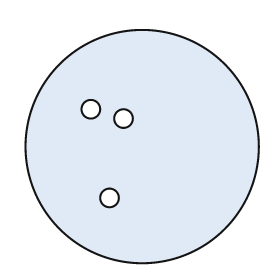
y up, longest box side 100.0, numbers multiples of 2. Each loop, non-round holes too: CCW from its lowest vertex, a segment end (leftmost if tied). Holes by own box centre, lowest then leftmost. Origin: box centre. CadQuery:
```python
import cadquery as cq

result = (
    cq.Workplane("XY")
    .moveTo(0.0, 0.0)
    .circle(50.0)
    .moveTo(-14.0, -22.0)
    .circle(4.0)
    .moveTo(-8.0, 12.0)
    .circle(4.0)
    .moveTo(-22.0, 16.0)
    .circle(4.0)
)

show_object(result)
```